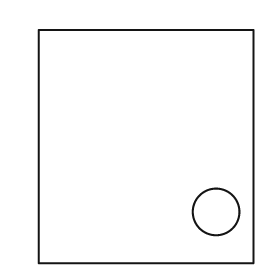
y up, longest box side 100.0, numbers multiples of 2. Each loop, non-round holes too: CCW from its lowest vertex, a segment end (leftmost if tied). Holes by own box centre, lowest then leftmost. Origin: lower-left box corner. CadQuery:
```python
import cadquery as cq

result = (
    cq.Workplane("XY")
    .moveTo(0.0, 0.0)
    .lineTo(92.0, 0.0)
    .lineTo(92.0, 100.0)
    .lineTo(0.0, 100.0)
    .close()
    .moveTo(76.0, 22.0)
    .circle(10.0)
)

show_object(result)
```